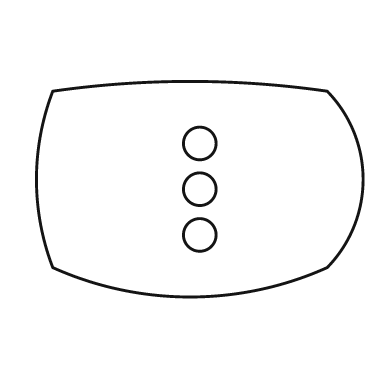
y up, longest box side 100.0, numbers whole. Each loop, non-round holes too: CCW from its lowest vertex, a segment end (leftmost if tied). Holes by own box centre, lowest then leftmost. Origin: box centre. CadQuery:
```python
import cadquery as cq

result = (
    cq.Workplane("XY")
    .moveTo(-45.0, -24.0)
    .threePointArc((-3.0, -33.0), (39.0, -24.0))
    .threePointArc((50.0, 3.0), (39.0, 30.0))
    .threePointArc((-3.0, 33.0), (-45.0, 30.0))
    .threePointArc((-50.0, 3.0), (-45.0, -24.0))
    .close()
    .moveTo(0.0, -14.0)
    .circle(5.0)
    .moveTo(0.0, 0.0)
    .circle(5.0)
    .moveTo(0.0, 14.0)
    .circle(5.0)
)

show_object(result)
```